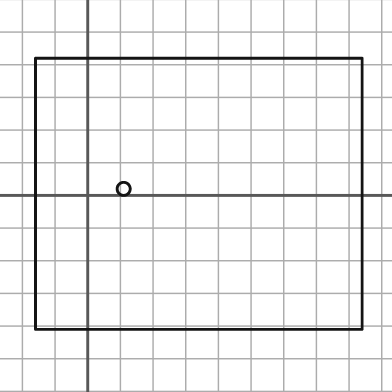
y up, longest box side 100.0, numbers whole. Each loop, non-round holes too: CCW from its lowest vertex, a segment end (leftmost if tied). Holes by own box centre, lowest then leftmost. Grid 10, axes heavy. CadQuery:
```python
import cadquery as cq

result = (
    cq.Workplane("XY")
    .moveTo(-16.0, -41.0)
    .lineTo(84.0, -41.0)
    .lineTo(84.0, 42.0)
    .lineTo(-16.0, 42.0)
    .close()
    .moveTo(11.0, 2.0)
    .circle(2.0)
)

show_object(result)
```